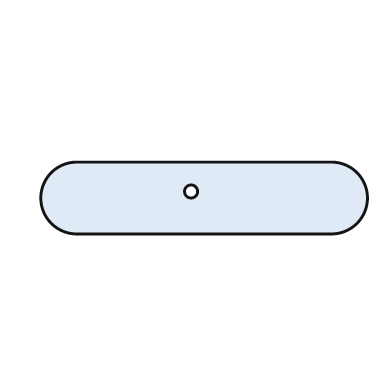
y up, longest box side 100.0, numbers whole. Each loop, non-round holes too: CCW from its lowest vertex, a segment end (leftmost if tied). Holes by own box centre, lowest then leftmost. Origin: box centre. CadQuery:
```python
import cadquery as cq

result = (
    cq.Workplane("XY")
    .moveTo(-39.0, -11.0)
    .lineTo(39.0, -11.0)
    .threePointArc((50.0, 0.0), (39.0, 11.0))
    .lineTo(-39.0, 11.0)
    .threePointArc((-50.0, 0.0), (-39.0, -11.0))
    .close()
    .moveTo(-4.0, 2.0)
    .circle(2.0)
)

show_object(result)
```